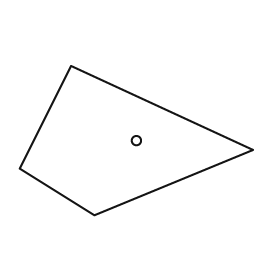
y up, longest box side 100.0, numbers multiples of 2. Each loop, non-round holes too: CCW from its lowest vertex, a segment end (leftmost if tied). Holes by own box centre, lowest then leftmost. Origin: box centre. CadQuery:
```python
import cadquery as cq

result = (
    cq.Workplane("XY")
    .moveTo(-18.0, -32.0)
    .lineTo(50.0, -4.0)
    .lineTo(-28.0, 32.0)
    .lineTo(-50.0, -12.0)
    .close()
    .moveTo(0.0, 0.0)
    .circle(2.0)
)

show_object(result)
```